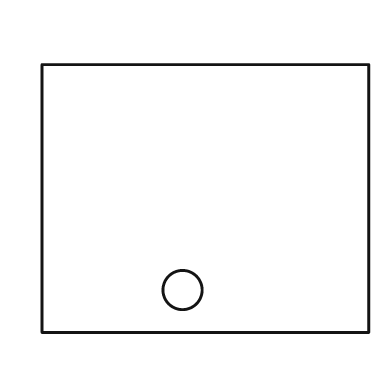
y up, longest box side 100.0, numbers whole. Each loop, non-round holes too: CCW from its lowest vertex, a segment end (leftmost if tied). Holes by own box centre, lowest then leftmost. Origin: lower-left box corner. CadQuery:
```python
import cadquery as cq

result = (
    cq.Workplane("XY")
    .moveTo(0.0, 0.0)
    .lineTo(100.0, 0.0)
    .lineTo(100.0, 82.0)
    .lineTo(0.0, 82.0)
    .close()
    .moveTo(43.0, 13.0)
    .circle(6.0)
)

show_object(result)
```